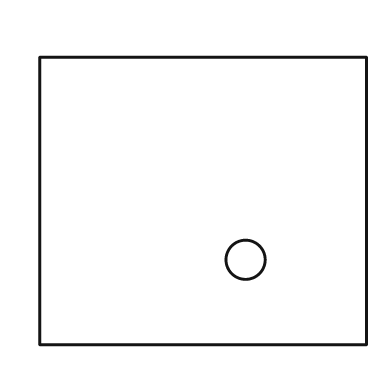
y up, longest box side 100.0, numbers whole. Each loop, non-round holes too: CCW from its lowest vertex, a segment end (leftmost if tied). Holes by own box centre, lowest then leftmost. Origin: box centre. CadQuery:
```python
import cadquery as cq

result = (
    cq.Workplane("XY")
    .moveTo(-50.0, -44.0)
    .lineTo(50.0, -44.0)
    .lineTo(50.0, 44.0)
    .lineTo(-50.0, 44.0)
    .close()
    .moveTo(13.0, -18.0)
    .circle(6.0)
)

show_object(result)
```